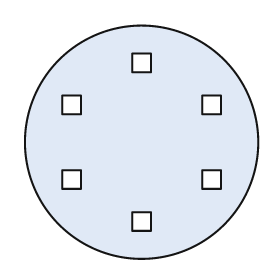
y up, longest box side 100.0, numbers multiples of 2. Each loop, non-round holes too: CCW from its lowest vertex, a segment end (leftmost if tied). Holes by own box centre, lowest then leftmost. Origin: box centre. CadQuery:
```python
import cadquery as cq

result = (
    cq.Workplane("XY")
    .moveTo(0.0, 0.0)
    .circle(50.0)
    .moveTo(-4.0, -38.0)
    .lineTo(4.0, -38.0)
    .lineTo(4.0, -30.0)
    .lineTo(-4.0, -30.0)
    .close()
    .moveTo(-34.0, -20.0)
    .lineTo(-26.0, -20.0)
    .lineTo(-26.0, -12.0)
    .lineTo(-34.0, -12.0)
    .close()
    .moveTo(26.0, -20.0)
    .lineTo(34.0, -20.0)
    .lineTo(34.0, -12.0)
    .lineTo(26.0, -12.0)
    .close()
    .moveTo(-34.0, 12.0)
    .lineTo(-26.0, 12.0)
    .lineTo(-26.0, 20.0)
    .lineTo(-34.0, 20.0)
    .close()
    .moveTo(26.0, 12.0)
    .lineTo(34.0, 12.0)
    .lineTo(34.0, 20.0)
    .lineTo(26.0, 20.0)
    .close()
    .moveTo(-4.0, 30.0)
    .lineTo(4.0, 30.0)
    .lineTo(4.0, 38.0)
    .lineTo(-4.0, 38.0)
    .close()
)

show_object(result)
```